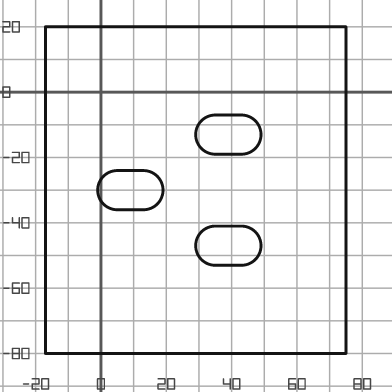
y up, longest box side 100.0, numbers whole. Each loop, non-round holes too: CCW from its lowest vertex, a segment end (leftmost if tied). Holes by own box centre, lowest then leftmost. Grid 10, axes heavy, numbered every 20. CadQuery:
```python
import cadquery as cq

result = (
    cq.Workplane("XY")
    .moveTo(-17.0, -80.0)
    .lineTo(75.0, -80.0)
    .lineTo(75.0, 20.0)
    .lineTo(-17.0, 20.0)
    .close()
    .moveTo(35.0, -53.0)
    .lineTo(43.0, -53.0)
    .threePointArc((49.0, -47.0), (43.0, -41.0))
    .lineTo(35.0, -41.0)
    .threePointArc((29.0, -47.0), (35.0, -53.0))
    .close()
    .moveTo(5.0, -36.0)
    .lineTo(13.0, -36.0)
    .threePointArc((19.0, -30.0), (13.0, -24.0))
    .lineTo(5.0, -24.0)
    .threePointArc((-1.0, -30.0), (5.0, -36.0))
    .close()
    .moveTo(35.0, -19.0)
    .lineTo(43.0, -19.0)
    .threePointArc((49.0, -13.0), (43.0, -7.0))
    .lineTo(35.0, -7.0)
    .threePointArc((29.0, -13.0), (35.0, -19.0))
    .close()
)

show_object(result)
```